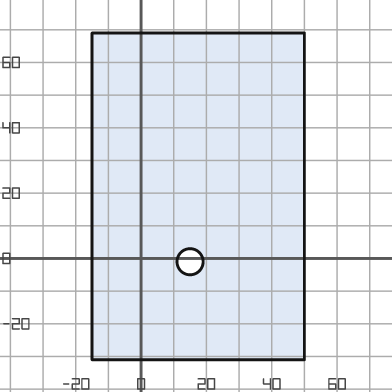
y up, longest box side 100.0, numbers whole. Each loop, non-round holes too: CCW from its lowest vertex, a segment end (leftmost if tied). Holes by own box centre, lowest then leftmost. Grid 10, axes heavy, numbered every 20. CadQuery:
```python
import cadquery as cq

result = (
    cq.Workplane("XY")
    .moveTo(-15.0, -31.0)
    .lineTo(50.0, -31.0)
    .lineTo(50.0, 69.0)
    .lineTo(-15.0, 69.0)
    .close()
    .moveTo(15.0, -1.0)
    .circle(4.0)
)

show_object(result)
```